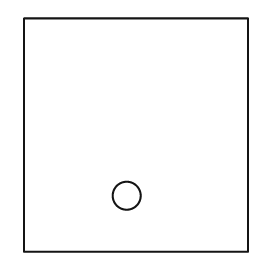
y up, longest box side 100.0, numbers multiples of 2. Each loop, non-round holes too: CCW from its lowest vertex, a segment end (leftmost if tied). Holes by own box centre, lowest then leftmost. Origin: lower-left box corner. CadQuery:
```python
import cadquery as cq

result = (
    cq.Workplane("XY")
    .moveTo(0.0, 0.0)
    .lineTo(96.0, 0.0)
    .lineTo(96.0, 100.0)
    .lineTo(0.0, 100.0)
    .close()
    .moveTo(44.0, 24.0)
    .circle(6.0)
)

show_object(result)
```